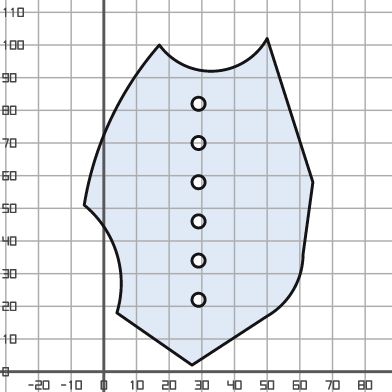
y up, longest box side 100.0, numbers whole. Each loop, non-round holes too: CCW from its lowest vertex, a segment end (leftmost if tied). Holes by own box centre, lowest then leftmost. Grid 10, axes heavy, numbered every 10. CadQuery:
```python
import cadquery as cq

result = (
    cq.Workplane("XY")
    .moveTo(27.0, 2.0)
    .lineTo(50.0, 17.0)
    .threePointArc((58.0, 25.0), (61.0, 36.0))
    .lineTo(64.0, 58.0)
    .lineTo(50.0, 102.0)
    .threePointArc((34.0, 92.0), (17.0, 100.0))
    .threePointArc((2.0, 77.0), (-6.0, 51.0))
    .threePointArc((4.0, 36.0), (4.0, 18.0))
    .close()
    .moveTo(29.0, 22.0)
    .circle(2.0)
    .moveTo(29.0, 34.0)
    .circle(2.0)
    .moveTo(29.0, 46.0)
    .circle(2.0)
    .moveTo(29.0, 58.0)
    .circle(2.0)
    .moveTo(29.0, 70.0)
    .circle(2.0)
    .moveTo(29.0, 82.0)
    .circle(2.0)
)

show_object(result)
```